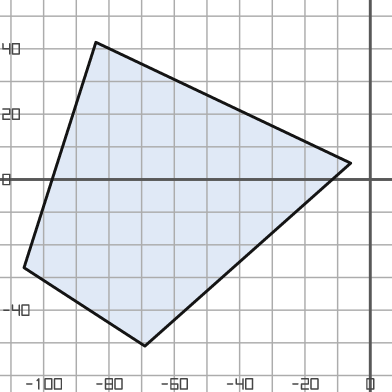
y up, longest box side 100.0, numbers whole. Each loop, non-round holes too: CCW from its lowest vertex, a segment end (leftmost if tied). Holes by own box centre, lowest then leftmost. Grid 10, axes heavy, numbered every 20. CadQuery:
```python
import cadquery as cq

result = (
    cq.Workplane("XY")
    .moveTo(-69.0, -51.0)
    .lineTo(-6.0, 5.0)
    .lineTo(-84.0, 42.0)
    .lineTo(-106.0, -27.0)
    .close()
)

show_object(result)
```